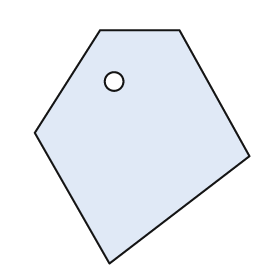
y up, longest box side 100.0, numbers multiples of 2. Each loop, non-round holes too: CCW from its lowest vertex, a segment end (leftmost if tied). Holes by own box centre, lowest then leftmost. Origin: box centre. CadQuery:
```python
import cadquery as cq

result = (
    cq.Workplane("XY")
    .moveTo(-14.0, -50.0)
    .lineTo(46.0, -4.0)
    .lineTo(16.0, 50.0)
    .lineTo(-18.0, 50.0)
    .lineTo(-46.0, 6.0)
    .close()
    .moveTo(-12.0, 28.0)
    .circle(4.0)
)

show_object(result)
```